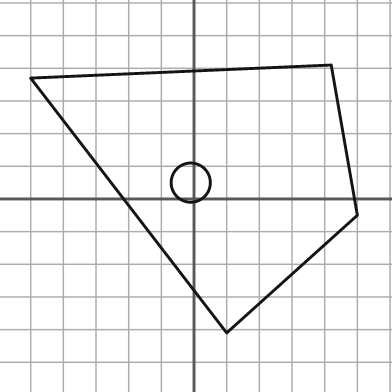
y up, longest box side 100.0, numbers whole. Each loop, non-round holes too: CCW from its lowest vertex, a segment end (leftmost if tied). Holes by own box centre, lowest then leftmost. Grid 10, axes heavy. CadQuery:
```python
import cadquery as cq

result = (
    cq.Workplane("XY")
    .moveTo(10.0, -41.0)
    .lineTo(50.0, -5.0)
    .lineTo(42.0, 41.0)
    .lineTo(-50.0, 37.0)
    .close()
    .moveTo(-1.0, 5.0)
    .circle(6.0)
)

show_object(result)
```